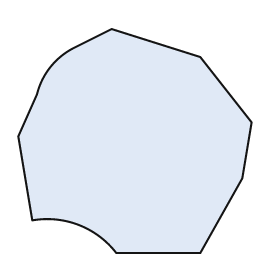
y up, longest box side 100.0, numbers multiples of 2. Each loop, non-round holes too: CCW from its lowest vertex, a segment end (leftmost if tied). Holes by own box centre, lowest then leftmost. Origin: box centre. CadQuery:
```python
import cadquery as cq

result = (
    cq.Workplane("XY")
    .moveTo(-8.0, -48.0)
    .lineTo(28.0, -48.0)
    .lineTo(46.0, -16.0)
    .lineTo(50.0, 8.0)
    .lineTo(28.0, 36.0)
    .lineTo(-10.0, 48.0)
    .lineTo(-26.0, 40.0)
    .threePointArc((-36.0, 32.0), (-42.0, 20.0))
    .lineTo(-50.0, 2.0)
    .lineTo(-44.0, -34.0)
    .threePointArc((-24.0, -36.0), (-8.0, -48.0))
    .close()
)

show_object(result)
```